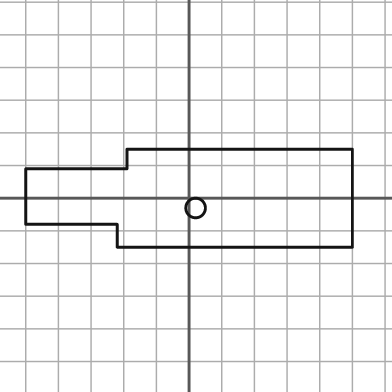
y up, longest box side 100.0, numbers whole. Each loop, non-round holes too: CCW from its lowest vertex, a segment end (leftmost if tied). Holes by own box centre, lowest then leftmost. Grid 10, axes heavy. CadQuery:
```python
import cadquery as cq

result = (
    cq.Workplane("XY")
    .moveTo(-22.0, -15.0)
    .lineTo(50.0, -15.0)
    .lineTo(50.0, 15.0)
    .lineTo(-19.0, 15.0)
    .lineTo(-19.0, 9.0)
    .lineTo(-50.0, 9.0)
    .lineTo(-50.0, -8.0)
    .lineTo(-22.0, -8.0)
    .close()
    .moveTo(2.0, -3.0)
    .circle(3.0)
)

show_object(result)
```